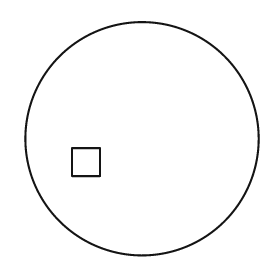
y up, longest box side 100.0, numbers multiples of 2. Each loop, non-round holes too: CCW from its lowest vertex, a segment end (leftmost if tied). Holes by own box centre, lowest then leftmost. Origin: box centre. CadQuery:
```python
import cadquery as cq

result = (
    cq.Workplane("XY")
    .moveTo(0.0, 0.0)
    .circle(50.0)
    .moveTo(-30.0, -16.0)
    .lineTo(-18.0, -16.0)
    .lineTo(-18.0, -4.0)
    .lineTo(-30.0, -4.0)
    .close()
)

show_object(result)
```